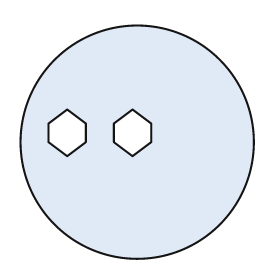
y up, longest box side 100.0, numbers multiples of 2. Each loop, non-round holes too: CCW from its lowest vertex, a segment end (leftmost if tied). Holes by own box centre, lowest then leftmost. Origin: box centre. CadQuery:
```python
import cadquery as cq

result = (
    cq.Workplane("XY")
    .moveTo(0.0, 0.0)
    .circle(50.0)
    .moveTo(-30.0, -6.0)
    .lineTo(-22.0, 0.0)
    .lineTo(-22.0, 8.0)
    .lineTo(-30.0, 14.0)
    .lineTo(-38.0, 8.0)
    .lineTo(-38.0, 0.0)
    .close()
    .moveTo(-2.0, -6.0)
    .lineTo(6.0, 0.0)
    .lineTo(6.0, 8.0)
    .lineTo(-2.0, 14.0)
    .lineTo(-10.0, 8.0)
    .lineTo(-10.0, 0.0)
    .close()
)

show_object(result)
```